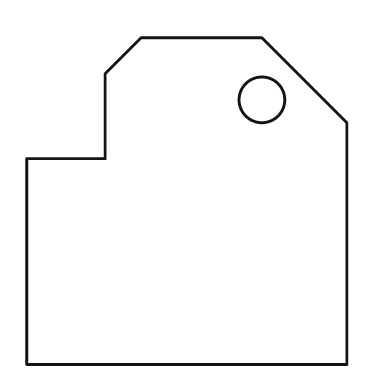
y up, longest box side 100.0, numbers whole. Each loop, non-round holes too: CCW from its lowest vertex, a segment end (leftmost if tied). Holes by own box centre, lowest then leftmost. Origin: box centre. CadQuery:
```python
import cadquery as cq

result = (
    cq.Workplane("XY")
    .moveTo(-49.0, -50.0)
    .lineTo(49.0, -50.0)
    .lineTo(49.0, 24.0)
    .lineTo(23.0, 50.0)
    .lineTo(-14.0, 50.0)
    .lineTo(-25.0, 39.0)
    .lineTo(-25.0, 13.0)
    .lineTo(-49.0, 13.0)
    .close()
    .moveTo(23.0, 31.0)
    .circle(7.0)
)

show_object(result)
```